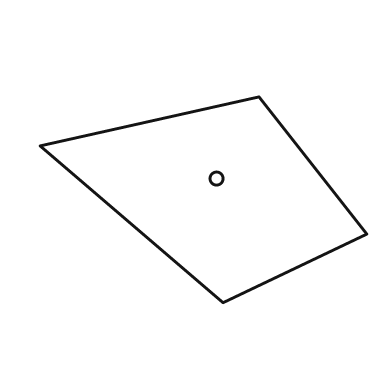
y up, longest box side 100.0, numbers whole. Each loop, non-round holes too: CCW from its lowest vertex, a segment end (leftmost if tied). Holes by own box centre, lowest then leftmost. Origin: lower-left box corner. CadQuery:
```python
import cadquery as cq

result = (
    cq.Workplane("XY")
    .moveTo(56.0, 0.0)
    .lineTo(100.0, 21.0)
    .lineTo(67.0, 63.0)
    .lineTo(0.0, 48.0)
    .close()
    .moveTo(54.0, 38.0)
    .circle(2.0)
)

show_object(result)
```